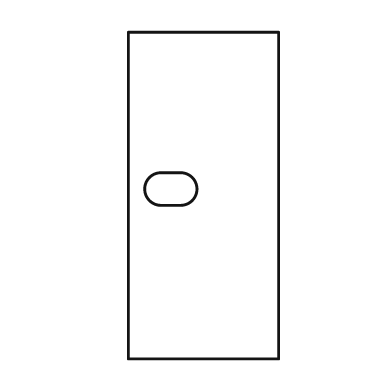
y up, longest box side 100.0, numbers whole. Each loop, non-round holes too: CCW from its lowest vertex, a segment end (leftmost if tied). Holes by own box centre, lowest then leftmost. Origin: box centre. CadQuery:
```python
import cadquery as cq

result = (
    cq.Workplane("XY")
    .moveTo(-23.0, -50.0)
    .lineTo(23.0, -50.0)
    .lineTo(23.0, 50.0)
    .lineTo(-23.0, 50.0)
    .close()
    .moveTo(-13.0, -3.0)
    .lineTo(-7.0, -3.0)
    .threePointArc((-2.0, 2.0), (-7.0, 7.0))
    .lineTo(-13.0, 7.0)
    .threePointArc((-18.0, 2.0), (-13.0, -3.0))
    .close()
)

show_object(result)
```